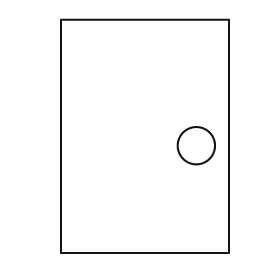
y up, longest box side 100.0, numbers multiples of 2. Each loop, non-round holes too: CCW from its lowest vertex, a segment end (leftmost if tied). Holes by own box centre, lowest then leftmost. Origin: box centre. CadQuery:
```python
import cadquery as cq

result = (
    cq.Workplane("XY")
    .moveTo(-36.0, -50.0)
    .lineTo(36.0, -50.0)
    .lineTo(36.0, 50.0)
    .lineTo(-36.0, 50.0)
    .close()
    .moveTo(22.0, -4.0)
    .circle(8.0)
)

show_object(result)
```